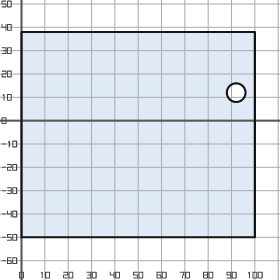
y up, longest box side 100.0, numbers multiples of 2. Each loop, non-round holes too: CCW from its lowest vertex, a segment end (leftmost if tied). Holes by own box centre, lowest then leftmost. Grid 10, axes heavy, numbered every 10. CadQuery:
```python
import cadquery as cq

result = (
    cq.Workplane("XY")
    .moveTo(0.0, -50.0)
    .lineTo(100.0, -50.0)
    .lineTo(100.0, 38.0)
    .lineTo(0.0, 38.0)
    .close()
    .moveTo(92.0, 12.0)
    .circle(4.0)
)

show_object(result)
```